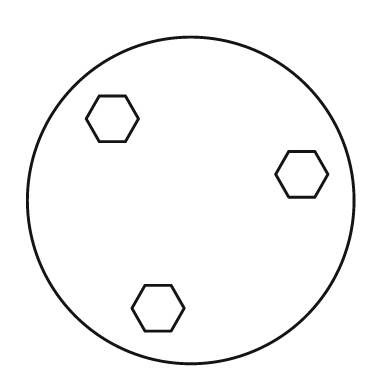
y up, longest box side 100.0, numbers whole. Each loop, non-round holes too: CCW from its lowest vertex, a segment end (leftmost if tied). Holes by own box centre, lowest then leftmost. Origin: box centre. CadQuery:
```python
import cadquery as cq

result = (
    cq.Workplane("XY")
    .moveTo(0.0, 0.0)
    .circle(50.0)
    .moveTo(-14.0, -40.0)
    .lineTo(-6.0, -40.0)
    .lineTo(-2.0, -33.0)
    .lineTo(-6.0, -26.0)
    .lineTo(-14.0, -26.0)
    .lineTo(-18.0, -33.0)
    .close()
    .moveTo(30.0, 1.0)
    .lineTo(38.0, 1.0)
    .lineTo(42.0, 8.0)
    .lineTo(38.0, 15.0)
    .lineTo(30.0, 15.0)
    .lineTo(26.0, 8.0)
    .close()
    .moveTo(-28.0, 18.0)
    .lineTo(-20.0, 18.0)
    .lineTo(-16.0, 25.0)
    .lineTo(-20.0, 32.0)
    .lineTo(-28.0, 32.0)
    .lineTo(-32.0, 25.0)
    .close()
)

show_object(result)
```